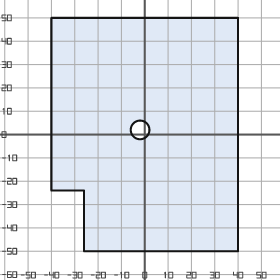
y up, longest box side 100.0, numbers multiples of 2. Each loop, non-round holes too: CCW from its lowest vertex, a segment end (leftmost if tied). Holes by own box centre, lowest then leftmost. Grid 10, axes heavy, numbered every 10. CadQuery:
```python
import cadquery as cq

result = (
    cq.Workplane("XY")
    .moveTo(-26.0, -50.0)
    .lineTo(40.0, -50.0)
    .lineTo(40.0, 50.0)
    .lineTo(-40.0, 50.0)
    .lineTo(-40.0, -24.0)
    .lineTo(-26.0, -24.0)
    .close()
    .moveTo(-2.0, 2.0)
    .circle(4.0)
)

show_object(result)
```